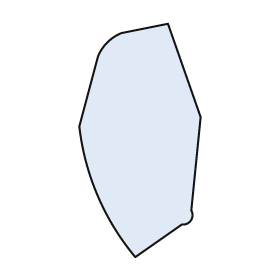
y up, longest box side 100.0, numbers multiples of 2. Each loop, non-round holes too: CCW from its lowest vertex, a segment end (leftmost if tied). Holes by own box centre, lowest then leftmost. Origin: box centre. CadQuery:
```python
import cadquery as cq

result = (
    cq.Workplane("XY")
    .moveTo(-2.0, -50.0)
    .lineTo(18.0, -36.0)
    .threePointArc((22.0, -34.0), (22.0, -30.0))
    .lineTo(26.0, 10.0)
    .lineTo(12.0, 50.0)
    .lineTo(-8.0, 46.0)
    .threePointArc((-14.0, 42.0), (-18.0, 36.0))
    .lineTo(-26.0, 6.0)
    .threePointArc((-18.0, -24.0), (-2.0, -50.0))
    .close()
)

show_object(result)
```